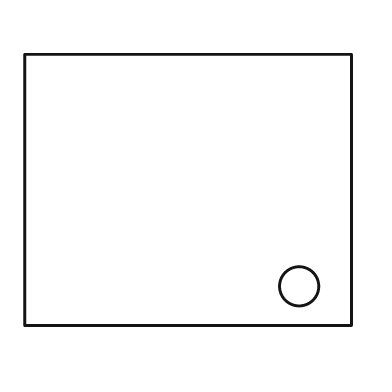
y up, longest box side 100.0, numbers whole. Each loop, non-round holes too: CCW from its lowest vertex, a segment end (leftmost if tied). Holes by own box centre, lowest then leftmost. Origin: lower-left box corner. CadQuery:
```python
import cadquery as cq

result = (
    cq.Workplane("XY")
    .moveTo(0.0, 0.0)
    .lineTo(100.0, 0.0)
    .lineTo(100.0, 83.0)
    .lineTo(0.0, 83.0)
    .close()
    .moveTo(84.0, 12.0)
    .circle(6.0)
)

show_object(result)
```